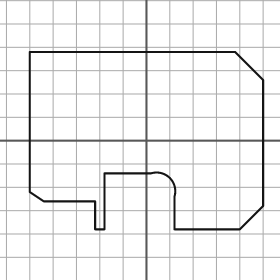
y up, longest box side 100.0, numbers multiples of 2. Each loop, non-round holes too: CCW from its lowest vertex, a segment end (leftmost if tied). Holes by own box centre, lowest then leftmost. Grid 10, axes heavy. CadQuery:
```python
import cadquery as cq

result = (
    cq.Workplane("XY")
    .moveTo(-22.0, -38.0)
    .lineTo(-18.0, -38.0)
    .lineTo(-18.0, -14.0)
    .lineTo(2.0, -14.0)
    .threePointArc((10.0, -16.0), (12.0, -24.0))
    .lineTo(12.0, -38.0)
    .lineTo(40.0, -38.0)
    .lineTo(50.0, -28.0)
    .lineTo(50.0, 26.0)
    .lineTo(38.0, 38.0)
    .lineTo(-50.0, 38.0)
    .lineTo(-50.0, -22.0)
    .lineTo(-44.0, -26.0)
    .lineTo(-22.0, -26.0)
    .close()
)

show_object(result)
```